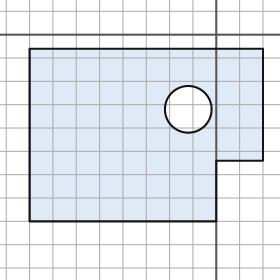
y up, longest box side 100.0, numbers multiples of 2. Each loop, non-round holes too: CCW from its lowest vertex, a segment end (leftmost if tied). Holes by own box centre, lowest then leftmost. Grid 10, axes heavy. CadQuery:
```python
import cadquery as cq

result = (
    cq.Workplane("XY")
    .moveTo(-80.0, -80.0)
    .lineTo(0.0, -80.0)
    .lineTo(0.0, -54.0)
    .lineTo(20.0, -54.0)
    .lineTo(20.0, -6.0)
    .lineTo(-80.0, -6.0)
    .close()
    .moveTo(-12.0, -32.0)
    .circle(10.0)
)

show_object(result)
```